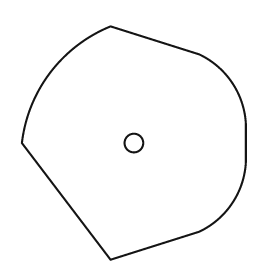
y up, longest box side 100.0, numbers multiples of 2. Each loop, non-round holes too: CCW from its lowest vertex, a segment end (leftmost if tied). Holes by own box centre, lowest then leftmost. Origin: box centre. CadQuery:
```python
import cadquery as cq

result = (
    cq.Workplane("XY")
    .moveTo(-10.0, -50.0)
    .lineTo(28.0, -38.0)
    .threePointArc((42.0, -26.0), (48.0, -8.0))
    .lineTo(48.0, 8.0)
    .threePointArc((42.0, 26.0), (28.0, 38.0))
    .lineTo(-10.0, 50.0)
    .threePointArc((-36.0, 30.0), (-48.0, 0.0))
    .close()
    .moveTo(0.0, 0.0)
    .circle(4.0)
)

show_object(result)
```